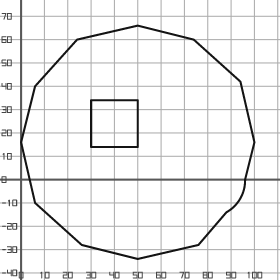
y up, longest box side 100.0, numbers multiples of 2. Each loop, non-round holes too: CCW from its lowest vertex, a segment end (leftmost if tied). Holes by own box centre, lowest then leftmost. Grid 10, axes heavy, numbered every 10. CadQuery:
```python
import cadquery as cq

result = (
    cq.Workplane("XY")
    .moveTo(50.0, -34.0)
    .lineTo(76.0, -28.0)
    .lineTo(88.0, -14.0)
    .threePointArc((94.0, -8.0), (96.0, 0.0))
    .lineTo(100.0, 16.0)
    .lineTo(94.0, 42.0)
    .lineTo(74.0, 60.0)
    .lineTo(50.0, 66.0)
    .lineTo(24.0, 60.0)
    .lineTo(6.0, 40.0)
    .lineTo(0.0, 16.0)
    .lineTo(6.0, -10.0)
    .lineTo(26.0, -28.0)
    .close()
    .moveTo(30.0, 14.0)
    .lineTo(50.0, 14.0)
    .lineTo(50.0, 34.0)
    .lineTo(30.0, 34.0)
    .close()
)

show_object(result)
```